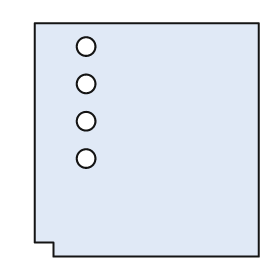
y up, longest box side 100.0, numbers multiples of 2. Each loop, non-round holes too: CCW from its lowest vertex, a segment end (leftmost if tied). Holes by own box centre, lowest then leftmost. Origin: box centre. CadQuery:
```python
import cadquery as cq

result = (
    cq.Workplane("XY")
    .moveTo(-40.0, -50.0)
    .lineTo(48.0, -50.0)
    .lineTo(48.0, 50.0)
    .lineTo(-48.0, 50.0)
    .lineTo(-48.0, -44.0)
    .lineTo(-40.0, -44.0)
    .close()
    .moveTo(-26.0, -8.0)
    .circle(4.0)
    .moveTo(-26.0, 8.0)
    .circle(4.0)
    .moveTo(-26.0, 24.0)
    .circle(4.0)
    .moveTo(-26.0, 40.0)
    .circle(4.0)
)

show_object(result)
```